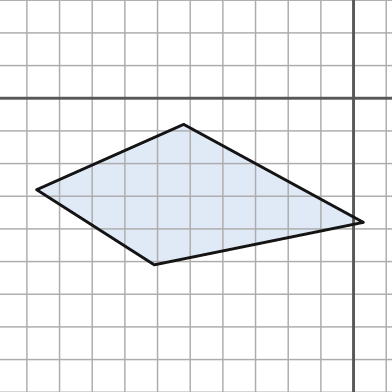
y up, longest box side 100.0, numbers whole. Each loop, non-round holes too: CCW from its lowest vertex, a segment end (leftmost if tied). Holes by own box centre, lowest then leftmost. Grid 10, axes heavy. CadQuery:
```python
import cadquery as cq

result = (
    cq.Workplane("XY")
    .moveTo(-61.0, -51.0)
    .lineTo(3.0, -38.0)
    .lineTo(-52.0, -8.0)
    .lineTo(-97.0, -28.0)
    .close()
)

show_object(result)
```